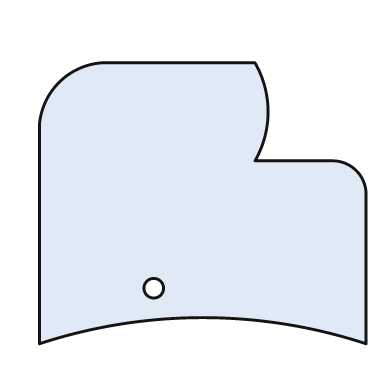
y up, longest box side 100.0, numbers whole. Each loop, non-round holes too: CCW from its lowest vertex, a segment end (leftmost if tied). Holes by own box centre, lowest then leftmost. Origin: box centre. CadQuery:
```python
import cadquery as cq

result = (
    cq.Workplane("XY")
    .moveTo(-50.0, -43.0)
    .threePointArc((0.0, -35.0), (50.0, -43.0))
    .lineTo(50.0, 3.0)
    .threePointArc((47.0, 10.0), (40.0, 13.0))
    .lineTo(16.0, 13.0)
    .threePointArc((20.0, 28.0), (16.0, 43.0))
    .lineTo(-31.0, 43.0)
    .threePointArc((-44.0, 37.0), (-50.0, 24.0))
    .close()
    .moveTo(-15.0, -26.0)
    .circle(3.0)
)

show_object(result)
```